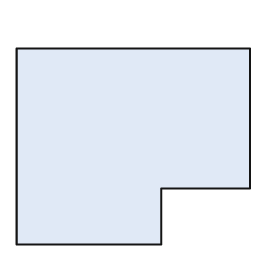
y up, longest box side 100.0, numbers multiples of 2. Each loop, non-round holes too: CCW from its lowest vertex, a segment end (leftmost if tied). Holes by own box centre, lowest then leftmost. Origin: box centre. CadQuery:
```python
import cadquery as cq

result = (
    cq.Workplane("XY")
    .moveTo(-50.0, -42.0)
    .lineTo(12.0, -42.0)
    .lineTo(12.0, -18.0)
    .lineTo(50.0, -18.0)
    .lineTo(50.0, 42.0)
    .lineTo(-50.0, 42.0)
    .close()
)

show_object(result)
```